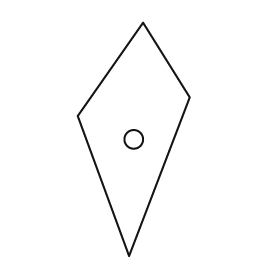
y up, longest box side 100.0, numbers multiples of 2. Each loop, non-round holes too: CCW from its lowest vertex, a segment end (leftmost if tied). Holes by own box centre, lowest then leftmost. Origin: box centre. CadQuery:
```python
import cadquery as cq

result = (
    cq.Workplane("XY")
    .moveTo(-2.0, -50.0)
    .lineTo(24.0, 18.0)
    .lineTo(4.0, 50.0)
    .lineTo(-24.0, 10.0)
    .close()
    .moveTo(0.0, 0.0)
    .circle(4.0)
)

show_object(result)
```